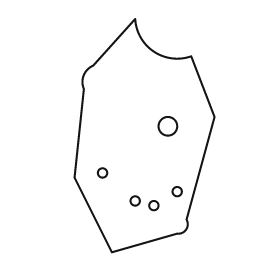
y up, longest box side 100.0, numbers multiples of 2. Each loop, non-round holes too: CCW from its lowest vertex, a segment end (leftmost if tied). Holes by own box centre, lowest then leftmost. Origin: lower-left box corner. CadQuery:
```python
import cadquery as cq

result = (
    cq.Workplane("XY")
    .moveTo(16.0, 0.0)
    .lineTo(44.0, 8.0)
    .threePointArc((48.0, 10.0), (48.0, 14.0))
    .lineTo(60.0, 58.0)
    .lineTo(50.0, 84.0)
    .threePointArc((34.0, 86.0), (26.0, 100.0))
    .lineTo(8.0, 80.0)
    .threePointArc((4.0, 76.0), (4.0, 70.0))
    .lineTo(0.0, 32.0)
    .close()
    .moveTo(34.0, 20.0)
    .circle(2.0)
    .moveTo(26.0, 22.0)
    .circle(2.0)
    .moveTo(44.0, 26.0)
    .circle(2.0)
    .moveTo(12.0, 34.0)
    .circle(2.0)
    .moveTo(40.0, 54.0)
    .circle(4.0)
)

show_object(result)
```